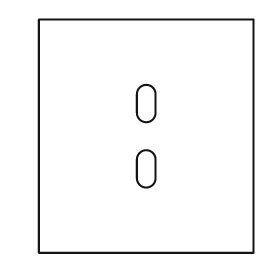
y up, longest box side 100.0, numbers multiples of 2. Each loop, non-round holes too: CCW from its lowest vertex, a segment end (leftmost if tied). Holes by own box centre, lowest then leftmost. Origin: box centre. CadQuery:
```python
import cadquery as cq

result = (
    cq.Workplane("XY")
    .moveTo(-46.0, -50.0)
    .lineTo(46.0, -50.0)
    .lineTo(46.0, 50.0)
    .lineTo(-46.0, 50.0)
    .close()
    .moveTo(-4.0, -18.0)
    .threePointArc((0.0, -22.0), (4.0, -18.0))
    .lineTo(4.0, -10.0)
    .threePointArc((0.0, -6.0), (-4.0, -10.0))
    .close()
    .moveTo(-4.0, 10.0)
    .threePointArc((0.0, 6.0), (4.0, 10.0))
    .lineTo(4.0, 18.0)
    .threePointArc((0.0, 22.0), (-4.0, 18.0))
    .close()
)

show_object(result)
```